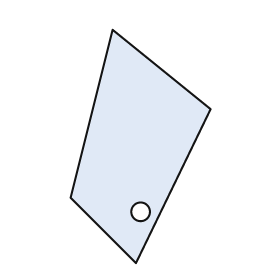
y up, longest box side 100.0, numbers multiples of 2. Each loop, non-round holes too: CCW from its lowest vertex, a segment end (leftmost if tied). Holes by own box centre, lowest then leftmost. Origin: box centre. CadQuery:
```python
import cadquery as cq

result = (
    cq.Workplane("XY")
    .moveTo(-2.0, -50.0)
    .lineTo(30.0, 16.0)
    .lineTo(-12.0, 50.0)
    .lineTo(-30.0, -22.0)
    .close()
    .moveTo(0.0, -28.0)
    .circle(4.0)
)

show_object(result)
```